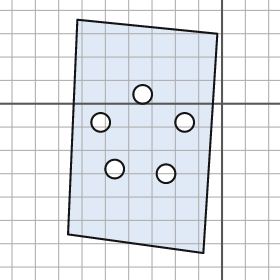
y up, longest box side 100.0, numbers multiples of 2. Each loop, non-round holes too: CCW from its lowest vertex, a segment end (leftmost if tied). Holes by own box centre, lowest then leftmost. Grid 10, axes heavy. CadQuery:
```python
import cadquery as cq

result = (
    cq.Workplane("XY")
    .moveTo(-8.0, -64.0)
    .lineTo(-2.0, 30.0)
    .lineTo(-62.0, 36.0)
    .lineTo(-66.0, -56.0)
    .close()
    .moveTo(-24.0, -30.0)
    .circle(4.0)
    .moveTo(-46.0, -28.0)
    .circle(4.0)
    .moveTo(-52.0, -8.0)
    .circle(4.0)
    .moveTo(-16.0, -8.0)
    .circle(4.0)
    .moveTo(-34.0, 4.0)
    .circle(4.0)
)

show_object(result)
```